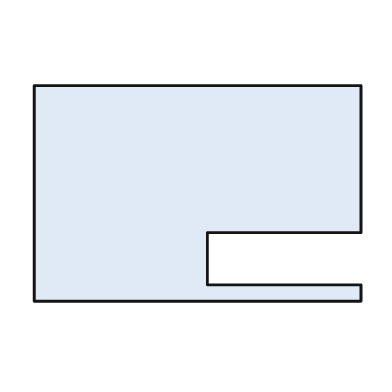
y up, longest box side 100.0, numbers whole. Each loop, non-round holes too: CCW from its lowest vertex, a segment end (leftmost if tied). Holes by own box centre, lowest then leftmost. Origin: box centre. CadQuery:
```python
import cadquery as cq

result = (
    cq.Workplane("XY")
    .moveTo(-50.0, -33.0)
    .lineTo(50.0, -33.0)
    .lineTo(50.0, -28.0)
    .lineTo(3.0, -28.0)
    .lineTo(3.0, -12.0)
    .lineTo(50.0, -12.0)
    .lineTo(50.0, 33.0)
    .lineTo(-50.0, 33.0)
    .close()
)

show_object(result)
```